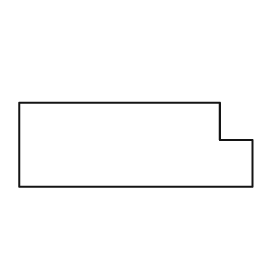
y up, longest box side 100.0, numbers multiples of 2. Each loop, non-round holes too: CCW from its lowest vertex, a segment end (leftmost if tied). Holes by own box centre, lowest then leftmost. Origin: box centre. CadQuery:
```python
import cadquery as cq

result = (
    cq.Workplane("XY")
    .moveTo(-50.0, -18.0)
    .lineTo(50.0, -18.0)
    .lineTo(50.0, 2.0)
    .lineTo(36.0, 2.0)
    .lineTo(36.0, 18.0)
    .lineTo(-50.0, 18.0)
    .close()
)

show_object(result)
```